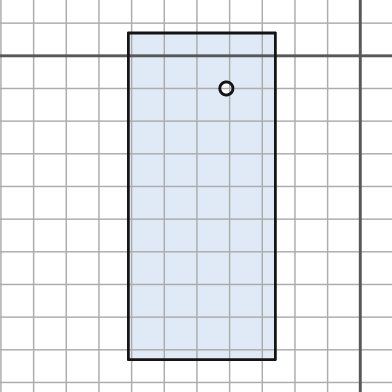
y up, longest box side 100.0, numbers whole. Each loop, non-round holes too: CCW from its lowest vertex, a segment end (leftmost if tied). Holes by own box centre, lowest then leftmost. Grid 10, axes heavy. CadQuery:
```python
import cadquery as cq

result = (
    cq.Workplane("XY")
    .moveTo(-71.0, -93.0)
    .lineTo(-26.0, -93.0)
    .lineTo(-26.0, 7.0)
    .lineTo(-71.0, 7.0)
    .close()
    .moveTo(-41.0, -10.0)
    .circle(2.0)
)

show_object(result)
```